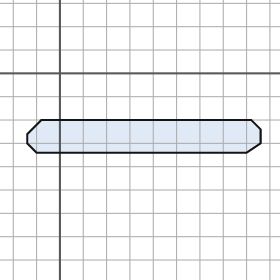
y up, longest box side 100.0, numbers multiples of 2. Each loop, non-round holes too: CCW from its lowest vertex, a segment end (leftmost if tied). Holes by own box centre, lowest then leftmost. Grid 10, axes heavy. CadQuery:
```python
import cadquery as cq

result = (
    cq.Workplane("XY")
    .moveTo(-10.0, -34.0)
    .lineTo(80.0, -34.0)
    .lineTo(86.0, -30.0)
    .lineTo(86.0, -24.0)
    .lineTo(82.0, -20.0)
    .lineTo(-8.0, -20.0)
    .lineTo(-14.0, -26.0)
    .lineTo(-14.0, -30.0)
    .close()
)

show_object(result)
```